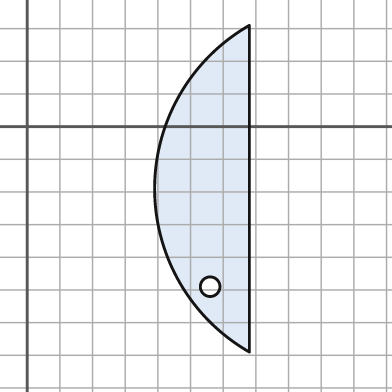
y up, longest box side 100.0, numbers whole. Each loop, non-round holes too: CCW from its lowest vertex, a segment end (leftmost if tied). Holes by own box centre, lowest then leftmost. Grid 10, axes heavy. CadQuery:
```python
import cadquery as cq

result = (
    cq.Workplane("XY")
    .moveTo(68.0, -69.0)
    .lineTo(68.0, 31.0)
    .threePointArc((39.0, -19.0), (68.0, -69.0))
    .close()
    .moveTo(56.0, -49.0)
    .circle(3.0)
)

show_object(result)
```